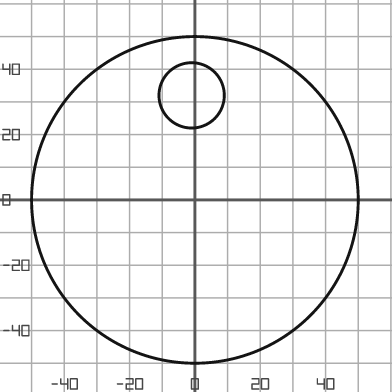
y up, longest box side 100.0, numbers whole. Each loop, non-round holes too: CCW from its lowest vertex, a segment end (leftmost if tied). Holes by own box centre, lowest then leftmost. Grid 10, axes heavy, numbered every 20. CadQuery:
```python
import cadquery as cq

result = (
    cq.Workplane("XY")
    .moveTo(0.0, 0.0)
    .circle(50.0)
    .moveTo(-1.0, 32.0)
    .circle(10.0)
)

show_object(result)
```